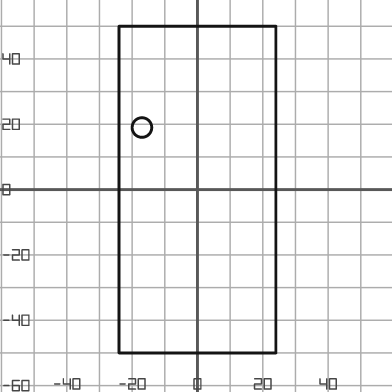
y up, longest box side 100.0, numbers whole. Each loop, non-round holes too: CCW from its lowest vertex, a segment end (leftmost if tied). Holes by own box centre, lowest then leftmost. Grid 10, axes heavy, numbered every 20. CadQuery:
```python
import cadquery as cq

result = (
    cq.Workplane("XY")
    .moveTo(-24.0, -50.0)
    .lineTo(24.0, -50.0)
    .lineTo(24.0, 50.0)
    .lineTo(-24.0, 50.0)
    .close()
    .moveTo(-17.0, 19.0)
    .circle(3.0)
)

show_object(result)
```